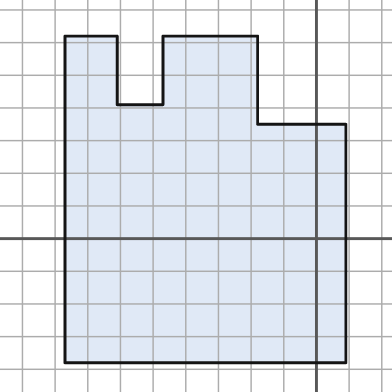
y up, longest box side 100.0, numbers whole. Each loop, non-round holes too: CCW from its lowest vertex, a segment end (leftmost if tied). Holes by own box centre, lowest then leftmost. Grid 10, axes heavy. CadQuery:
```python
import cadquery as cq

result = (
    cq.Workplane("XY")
    .moveTo(-77.0, -38.0)
    .lineTo(9.0, -38.0)
    .lineTo(9.0, 35.0)
    .lineTo(-18.0, 35.0)
    .lineTo(-18.0, 62.0)
    .lineTo(-47.0, 62.0)
    .lineTo(-47.0, 41.0)
    .lineTo(-61.0, 41.0)
    .lineTo(-61.0, 62.0)
    .lineTo(-77.0, 62.0)
    .close()
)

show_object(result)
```